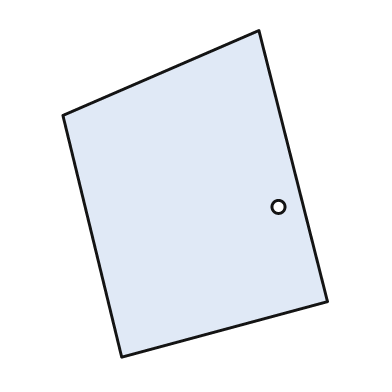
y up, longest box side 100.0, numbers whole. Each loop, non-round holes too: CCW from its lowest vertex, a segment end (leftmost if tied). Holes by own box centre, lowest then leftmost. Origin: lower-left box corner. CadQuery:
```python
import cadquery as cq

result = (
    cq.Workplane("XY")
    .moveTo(18.0, 0.0)
    .lineTo(81.0, 17.0)
    .lineTo(60.0, 100.0)
    .lineTo(0.0, 74.0)
    .close()
    .moveTo(66.0, 46.0)
    .circle(2.0)
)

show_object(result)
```